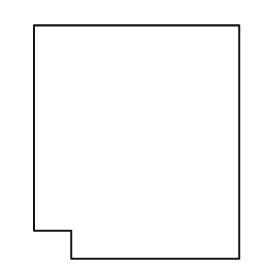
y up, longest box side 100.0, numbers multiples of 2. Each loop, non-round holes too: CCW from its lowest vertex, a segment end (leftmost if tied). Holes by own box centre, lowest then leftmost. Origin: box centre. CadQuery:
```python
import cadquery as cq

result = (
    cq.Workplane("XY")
    .moveTo(-28.0, -50.0)
    .lineTo(44.0, -50.0)
    .lineTo(44.0, 50.0)
    .lineTo(-44.0, 50.0)
    .lineTo(-44.0, -38.0)
    .lineTo(-28.0, -38.0)
    .close()
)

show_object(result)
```